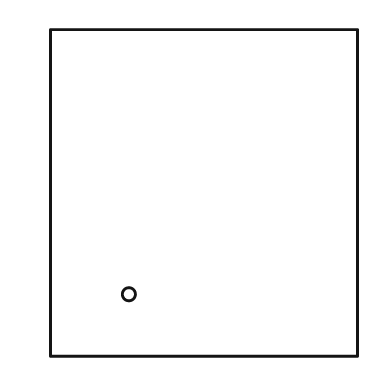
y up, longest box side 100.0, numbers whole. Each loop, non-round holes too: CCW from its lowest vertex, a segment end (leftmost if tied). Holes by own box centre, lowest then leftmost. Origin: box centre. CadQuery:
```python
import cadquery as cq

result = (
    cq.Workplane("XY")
    .moveTo(-47.0, -50.0)
    .lineTo(47.0, -50.0)
    .lineTo(47.0, 50.0)
    .lineTo(-47.0, 50.0)
    .close()
    .moveTo(-23.0, -31.0)
    .circle(2.0)
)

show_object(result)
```